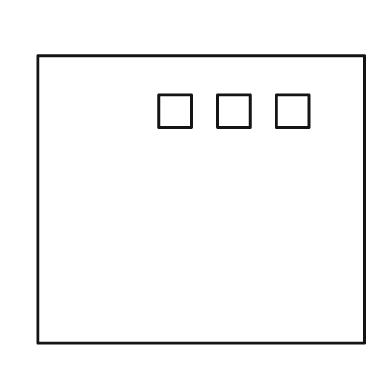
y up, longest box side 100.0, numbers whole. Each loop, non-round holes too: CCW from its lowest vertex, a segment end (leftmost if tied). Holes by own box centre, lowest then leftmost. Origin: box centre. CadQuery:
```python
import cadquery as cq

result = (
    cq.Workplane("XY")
    .moveTo(-50.0, -44.0)
    .lineTo(50.0, -44.0)
    .lineTo(50.0, 44.0)
    .lineTo(-50.0, 44.0)
    .close()
    .moveTo(-13.0, 22.0)
    .lineTo(-3.0, 22.0)
    .lineTo(-3.0, 32.0)
    .lineTo(-13.0, 32.0)
    .close()
    .moveTo(5.0, 22.0)
    .lineTo(15.0, 22.0)
    .lineTo(15.0, 32.0)
    .lineTo(5.0, 32.0)
    .close()
    .moveTo(23.0, 22.0)
    .lineTo(33.0, 22.0)
    .lineTo(33.0, 32.0)
    .lineTo(23.0, 32.0)
    .close()
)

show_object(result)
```